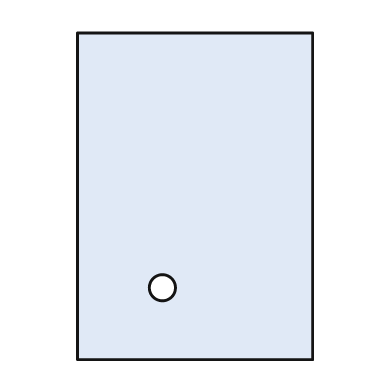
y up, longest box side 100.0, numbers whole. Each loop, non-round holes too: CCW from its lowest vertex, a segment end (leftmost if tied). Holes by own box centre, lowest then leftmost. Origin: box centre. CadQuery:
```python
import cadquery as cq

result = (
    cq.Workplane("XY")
    .moveTo(-36.0, -50.0)
    .lineTo(36.0, -50.0)
    .lineTo(36.0, 50.0)
    .lineTo(-36.0, 50.0)
    .close()
    .moveTo(-10.0, -28.0)
    .circle(4.0)
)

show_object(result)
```